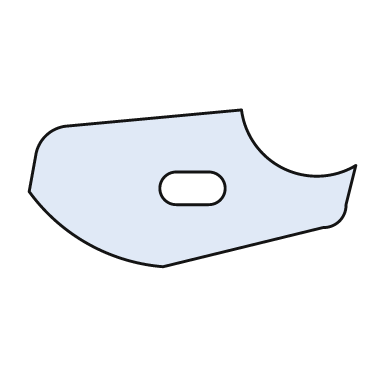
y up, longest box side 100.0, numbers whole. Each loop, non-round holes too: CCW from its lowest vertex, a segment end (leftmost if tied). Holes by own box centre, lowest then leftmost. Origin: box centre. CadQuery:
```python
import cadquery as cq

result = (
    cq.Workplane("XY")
    .moveTo(-9.0, -24.0)
    .lineTo(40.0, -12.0)
    .threePointArc((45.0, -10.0), (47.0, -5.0))
    .lineTo(50.0, 7.0)
    .threePointArc((28.0, 6.0), (15.0, 24.0))
    .lineTo(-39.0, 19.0)
    .threePointArc((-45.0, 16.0), (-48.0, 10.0))
    .lineTo(-50.0, -1.0)
    .threePointArc((-32.0, -17.0), (-9.0, -24.0))
    .close()
    .moveTo(-5.0, -5.0)
    .lineTo(5.0, -5.0)
    .threePointArc((10.0, 0.0), (5.0, 5.0))
    .lineTo(-5.0, 5.0)
    .threePointArc((-10.0, 0.0), (-5.0, -5.0))
    .close()
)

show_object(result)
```